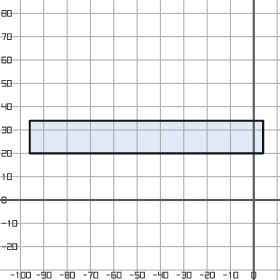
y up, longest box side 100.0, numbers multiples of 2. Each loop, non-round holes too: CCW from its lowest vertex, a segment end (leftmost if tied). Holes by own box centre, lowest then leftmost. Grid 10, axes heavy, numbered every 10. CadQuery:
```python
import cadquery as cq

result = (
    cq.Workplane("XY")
    .moveTo(-96.0, 20.0)
    .lineTo(4.0, 20.0)
    .lineTo(4.0, 34.0)
    .lineTo(-96.0, 34.0)
    .close()
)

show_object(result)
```